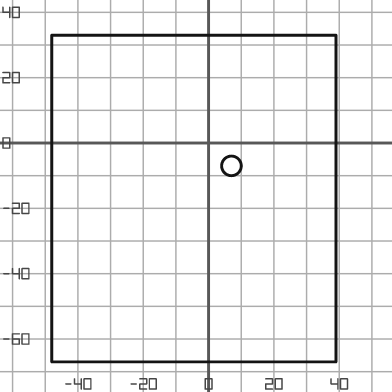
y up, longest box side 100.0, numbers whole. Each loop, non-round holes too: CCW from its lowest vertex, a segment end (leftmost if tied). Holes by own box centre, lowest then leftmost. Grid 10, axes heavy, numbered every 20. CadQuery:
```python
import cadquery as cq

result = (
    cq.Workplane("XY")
    .moveTo(-48.0, -67.0)
    .lineTo(39.0, -67.0)
    .lineTo(39.0, 33.0)
    .lineTo(-48.0, 33.0)
    .close()
    .moveTo(7.0, -7.0)
    .circle(3.0)
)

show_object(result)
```